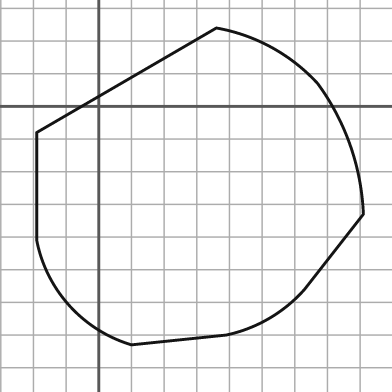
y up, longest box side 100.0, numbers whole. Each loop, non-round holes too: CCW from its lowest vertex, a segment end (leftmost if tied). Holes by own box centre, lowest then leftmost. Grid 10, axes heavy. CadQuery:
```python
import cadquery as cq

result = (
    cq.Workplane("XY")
    .moveTo(10.0, -73.0)
    .lineTo(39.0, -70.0)
    .threePointArc((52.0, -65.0), (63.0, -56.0))
    .lineTo(81.0, -33.0)
    .threePointArc((77.0, -12.0), (67.0, 7.0))
    .threePointArc((53.0, 18.0), (36.0, 24.0))
    .lineTo(-19.0, -8.0)
    .lineTo(-19.0, -41.0)
    .threePointArc((-9.0, -61.0), (10.0, -73.0))
    .close()
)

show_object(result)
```